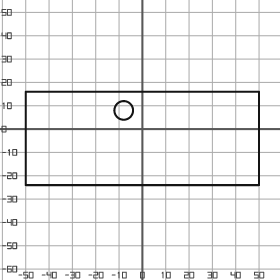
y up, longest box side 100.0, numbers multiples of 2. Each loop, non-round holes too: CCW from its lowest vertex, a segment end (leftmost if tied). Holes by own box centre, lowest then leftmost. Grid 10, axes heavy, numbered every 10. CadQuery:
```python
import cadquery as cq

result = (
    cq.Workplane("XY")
    .moveTo(-50.0, -24.0)
    .lineTo(50.0, -24.0)
    .lineTo(50.0, 16.0)
    .lineTo(-50.0, 16.0)
    .close()
    .moveTo(-8.0, 8.0)
    .circle(4.0)
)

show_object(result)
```